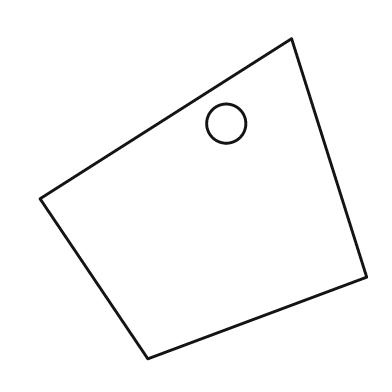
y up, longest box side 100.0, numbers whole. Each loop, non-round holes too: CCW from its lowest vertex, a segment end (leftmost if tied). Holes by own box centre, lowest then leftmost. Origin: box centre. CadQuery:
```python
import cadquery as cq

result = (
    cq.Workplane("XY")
    .moveTo(-17.0, -49.0)
    .lineTo(50.0, -24.0)
    .lineTo(27.0, 49.0)
    .lineTo(-50.0, 0.0)
    .close()
    .moveTo(7.0, 23.0)
    .circle(6.0)
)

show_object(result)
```